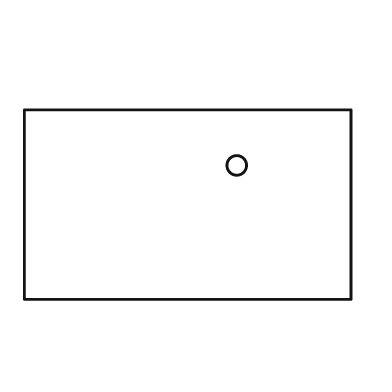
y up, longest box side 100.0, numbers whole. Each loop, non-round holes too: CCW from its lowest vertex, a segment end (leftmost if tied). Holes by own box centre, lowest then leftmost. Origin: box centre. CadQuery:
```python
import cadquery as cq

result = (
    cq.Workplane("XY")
    .moveTo(-50.0, -29.0)
    .lineTo(50.0, -29.0)
    .lineTo(50.0, 29.0)
    .lineTo(-50.0, 29.0)
    .close()
    .moveTo(15.0, 12.0)
    .circle(3.0)
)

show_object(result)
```